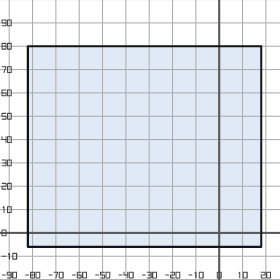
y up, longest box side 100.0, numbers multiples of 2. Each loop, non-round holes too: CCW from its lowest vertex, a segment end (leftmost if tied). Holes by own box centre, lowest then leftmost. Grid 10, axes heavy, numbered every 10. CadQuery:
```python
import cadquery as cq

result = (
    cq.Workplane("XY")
    .moveTo(-82.0, -6.0)
    .lineTo(18.0, -6.0)
    .lineTo(18.0, 80.0)
    .lineTo(-82.0, 80.0)
    .close()
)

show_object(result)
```